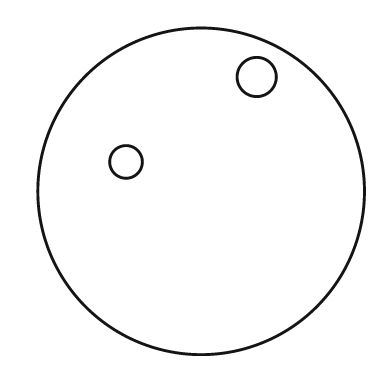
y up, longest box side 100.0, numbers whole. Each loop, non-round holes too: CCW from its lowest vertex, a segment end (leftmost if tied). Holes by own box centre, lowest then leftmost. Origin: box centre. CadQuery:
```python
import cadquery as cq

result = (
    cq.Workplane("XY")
    .moveTo(0.0, 0.0)
    .circle(50.0)
    .moveTo(-23.0, 9.0)
    .circle(5.0)
    .moveTo(17.0, 35.0)
    .circle(6.0)
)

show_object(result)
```